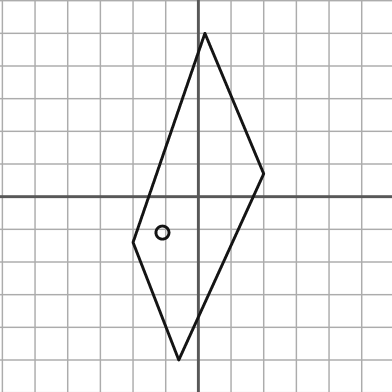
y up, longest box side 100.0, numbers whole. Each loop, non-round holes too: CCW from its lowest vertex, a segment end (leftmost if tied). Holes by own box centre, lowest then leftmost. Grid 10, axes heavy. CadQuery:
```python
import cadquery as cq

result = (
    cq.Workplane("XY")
    .moveTo(-6.0, -50.0)
    .lineTo(20.0, 7.0)
    .lineTo(2.0, 50.0)
    .lineTo(-20.0, -14.0)
    .close()
    .moveTo(-11.0, -11.0)
    .circle(2.0)
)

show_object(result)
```